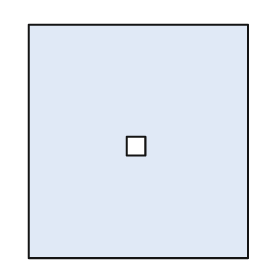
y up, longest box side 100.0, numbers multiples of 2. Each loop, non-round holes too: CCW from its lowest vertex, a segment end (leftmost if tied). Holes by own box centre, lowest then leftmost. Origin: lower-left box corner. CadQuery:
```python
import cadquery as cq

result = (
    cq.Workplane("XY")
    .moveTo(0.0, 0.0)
    .lineTo(94.0, 0.0)
    .lineTo(94.0, 100.0)
    .lineTo(0.0, 100.0)
    .close()
    .moveTo(42.0, 44.0)
    .lineTo(50.0, 44.0)
    .lineTo(50.0, 52.0)
    .lineTo(42.0, 52.0)
    .close()
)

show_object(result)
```